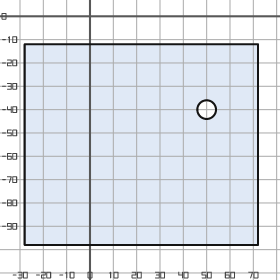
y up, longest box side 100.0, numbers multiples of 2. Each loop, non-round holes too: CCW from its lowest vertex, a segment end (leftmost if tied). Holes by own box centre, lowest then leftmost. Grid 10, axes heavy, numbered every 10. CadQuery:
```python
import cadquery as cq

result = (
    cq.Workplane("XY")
    .moveTo(-28.0, -98.0)
    .lineTo(72.0, -98.0)
    .lineTo(72.0, -12.0)
    .lineTo(-28.0, -12.0)
    .close()
    .moveTo(50.0, -40.0)
    .circle(4.0)
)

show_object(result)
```